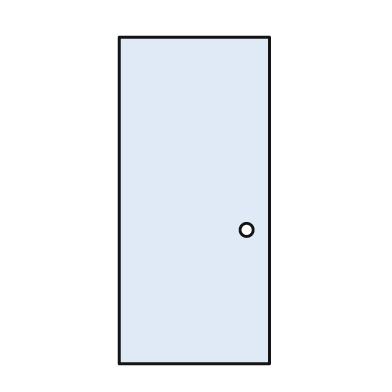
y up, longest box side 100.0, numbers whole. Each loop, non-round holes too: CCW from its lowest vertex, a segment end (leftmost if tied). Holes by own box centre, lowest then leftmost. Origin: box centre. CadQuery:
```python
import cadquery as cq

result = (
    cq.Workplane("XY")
    .moveTo(-23.0, -50.0)
    .lineTo(23.0, -50.0)
    .lineTo(23.0, 50.0)
    .lineTo(-23.0, 50.0)
    .close()
    .moveTo(16.0, -9.0)
    .circle(2.0)
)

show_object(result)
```